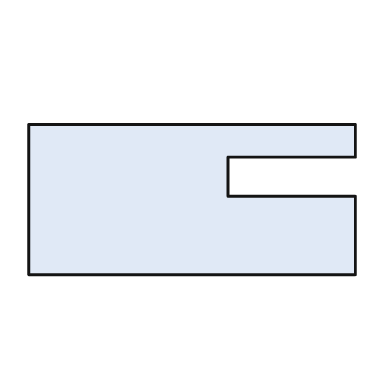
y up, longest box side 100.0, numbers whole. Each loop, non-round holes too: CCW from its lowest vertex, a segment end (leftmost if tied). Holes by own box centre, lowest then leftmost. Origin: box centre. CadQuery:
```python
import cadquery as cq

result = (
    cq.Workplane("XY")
    .moveTo(-50.0, -23.0)
    .lineTo(50.0, -23.0)
    .lineTo(50.0, 1.0)
    .lineTo(11.0, 1.0)
    .lineTo(11.0, 13.0)
    .lineTo(50.0, 13.0)
    .lineTo(50.0, 23.0)
    .lineTo(-50.0, 23.0)
    .close()
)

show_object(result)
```